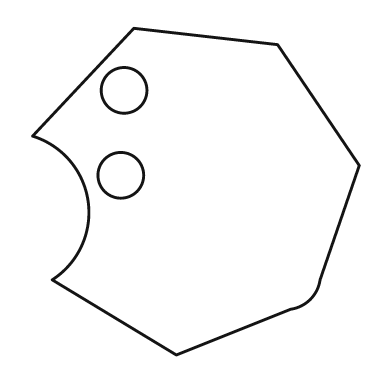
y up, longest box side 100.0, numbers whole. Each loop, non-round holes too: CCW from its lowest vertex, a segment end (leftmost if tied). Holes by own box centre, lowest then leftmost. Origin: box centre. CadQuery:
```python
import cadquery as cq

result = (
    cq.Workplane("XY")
    .moveTo(-6.0, -50.0)
    .lineTo(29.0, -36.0)
    .threePointArc((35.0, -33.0), (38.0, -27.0))
    .lineTo(50.0, 8.0)
    .lineTo(25.0, 45.0)
    .lineTo(-19.0, 50.0)
    .lineTo(-50.0, 17.0)
    .threePointArc((-33.0, -3.0), (-44.0, -27.0))
    .close()
    .moveTo(-23.0, 5.0)
    .circle(7.0)
    .moveTo(-22.0, 31.0)
    .circle(7.0)
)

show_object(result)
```